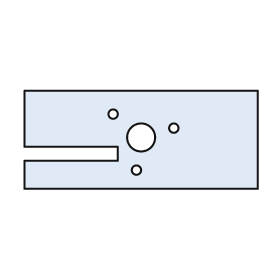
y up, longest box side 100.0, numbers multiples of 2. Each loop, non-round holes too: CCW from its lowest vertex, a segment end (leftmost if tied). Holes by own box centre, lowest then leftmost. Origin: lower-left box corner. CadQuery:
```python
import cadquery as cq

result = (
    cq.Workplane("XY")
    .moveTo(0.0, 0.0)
    .lineTo(100.0, 0.0)
    .lineTo(100.0, 42.0)
    .lineTo(0.0, 42.0)
    .lineTo(0.0, 18.0)
    .lineTo(40.0, 18.0)
    .lineTo(40.0, 12.0)
    .lineTo(0.0, 12.0)
    .close()
    .moveTo(48.0, 8.0)
    .circle(2.0)
    .moveTo(50.0, 22.0)
    .circle(6.0)
    .moveTo(64.0, 26.0)
    .circle(2.0)
    .moveTo(38.0, 32.0)
    .circle(2.0)
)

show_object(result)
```